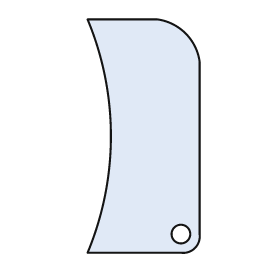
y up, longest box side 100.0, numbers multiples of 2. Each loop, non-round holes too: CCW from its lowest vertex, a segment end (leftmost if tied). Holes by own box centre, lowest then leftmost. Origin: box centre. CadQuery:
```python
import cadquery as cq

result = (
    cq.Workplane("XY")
    .moveTo(-24.0, -50.0)
    .lineTo(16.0, -50.0)
    .threePointArc((22.0, -48.0), (24.0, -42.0))
    .lineTo(24.0, 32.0)
    .threePointArc((18.0, 44.0), (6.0, 50.0))
    .lineTo(-24.0, 50.0)
    .threePointArc((-14.0, 0.0), (-24.0, -50.0))
    .close()
    .moveTo(16.0, -42.0)
    .circle(4.0)
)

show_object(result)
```